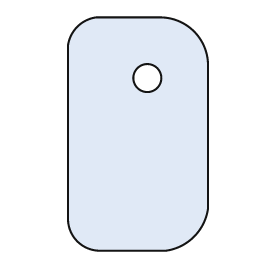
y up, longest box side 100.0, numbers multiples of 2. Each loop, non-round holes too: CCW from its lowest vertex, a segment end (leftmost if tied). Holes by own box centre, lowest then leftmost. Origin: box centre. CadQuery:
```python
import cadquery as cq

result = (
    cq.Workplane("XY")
    .moveTo(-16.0, -50.0)
    .lineTo(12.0, -50.0)
    .threePointArc((24.0, -44.0), (30.0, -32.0))
    .lineTo(30.0, 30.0)
    .threePointArc((24.0, 44.0), (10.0, 50.0))
    .lineTo(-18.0, 50.0)
    .threePointArc((-26.0, 46.0), (-30.0, 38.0))
    .lineTo(-30.0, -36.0)
    .threePointArc((-26.0, -46.0), (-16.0, -50.0))
    .close()
    .moveTo(4.0, 24.0)
    .circle(6.0)
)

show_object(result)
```